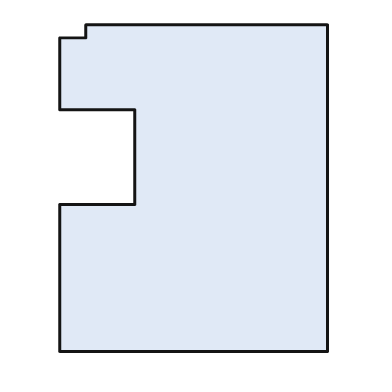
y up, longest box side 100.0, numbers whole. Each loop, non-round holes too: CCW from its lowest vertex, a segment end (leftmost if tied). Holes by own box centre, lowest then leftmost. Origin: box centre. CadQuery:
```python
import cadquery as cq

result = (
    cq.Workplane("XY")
    .moveTo(-41.0, -50.0)
    .lineTo(41.0, -50.0)
    .lineTo(41.0, 50.0)
    .lineTo(-33.0, 50.0)
    .lineTo(-33.0, 46.0)
    .lineTo(-41.0, 46.0)
    .lineTo(-41.0, 24.0)
    .lineTo(-18.0, 24.0)
    .lineTo(-18.0, -5.0)
    .lineTo(-41.0, -5.0)
    .close()
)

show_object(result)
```